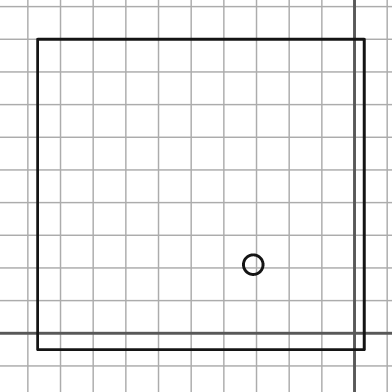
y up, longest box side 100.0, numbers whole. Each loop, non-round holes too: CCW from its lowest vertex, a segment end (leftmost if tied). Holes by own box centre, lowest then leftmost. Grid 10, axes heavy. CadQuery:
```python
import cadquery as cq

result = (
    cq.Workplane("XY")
    .moveTo(-97.0, -5.0)
    .lineTo(3.0, -5.0)
    .lineTo(3.0, 90.0)
    .lineTo(-97.0, 90.0)
    .close()
    .moveTo(-31.0, 21.0)
    .circle(3.0)
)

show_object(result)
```